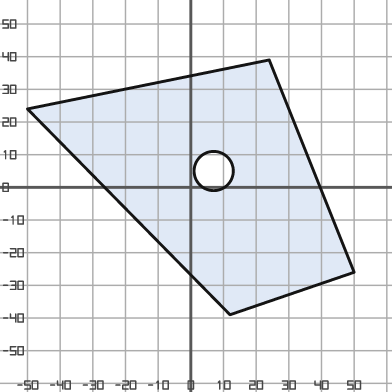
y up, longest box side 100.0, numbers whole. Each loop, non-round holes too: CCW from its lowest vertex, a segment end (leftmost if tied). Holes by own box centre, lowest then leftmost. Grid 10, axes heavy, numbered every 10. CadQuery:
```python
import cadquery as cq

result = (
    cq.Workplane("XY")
    .moveTo(12.0, -39.0)
    .lineTo(50.0, -26.0)
    .lineTo(24.0, 39.0)
    .lineTo(-50.0, 24.0)
    .close()
    .moveTo(7.0, 5.0)
    .circle(6.0)
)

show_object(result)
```